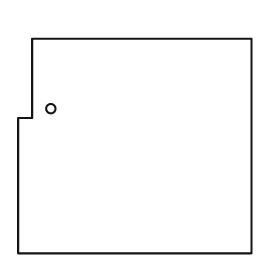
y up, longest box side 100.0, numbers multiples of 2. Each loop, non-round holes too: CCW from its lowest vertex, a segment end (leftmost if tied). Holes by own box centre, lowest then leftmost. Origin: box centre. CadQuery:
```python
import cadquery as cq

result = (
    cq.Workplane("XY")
    .moveTo(-50.0, -46.0)
    .lineTo(50.0, -46.0)
    .lineTo(50.0, 46.0)
    .lineTo(-44.0, 46.0)
    .lineTo(-44.0, 12.0)
    .lineTo(-50.0, 12.0)
    .close()
    .moveTo(-36.0, 16.0)
    .circle(2.0)
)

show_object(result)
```